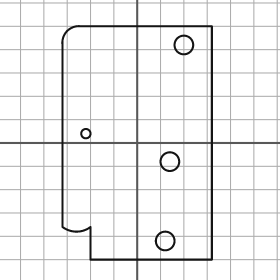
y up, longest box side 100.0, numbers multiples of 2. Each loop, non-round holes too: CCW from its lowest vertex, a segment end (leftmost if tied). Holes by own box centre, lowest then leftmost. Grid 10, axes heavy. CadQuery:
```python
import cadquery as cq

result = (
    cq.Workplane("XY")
    .moveTo(-20.0, -50.0)
    .lineTo(32.0, -50.0)
    .lineTo(32.0, 50.0)
    .lineTo(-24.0, 50.0)
    .threePointArc((-30.0, 48.0), (-32.0, 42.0))
    .lineTo(-32.0, -36.0)
    .threePointArc((-26.0, -38.0), (-20.0, -36.0))
    .close()
    .moveTo(12.0, -42.0)
    .circle(4.0)
    .moveTo(14.0, -8.0)
    .circle(4.0)
    .moveTo(-22.0, 4.0)
    .circle(2.0)
    .moveTo(20.0, 42.0)
    .circle(4.0)
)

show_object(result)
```